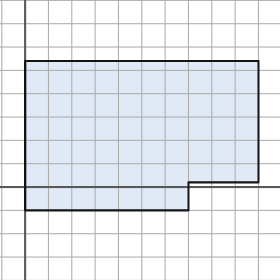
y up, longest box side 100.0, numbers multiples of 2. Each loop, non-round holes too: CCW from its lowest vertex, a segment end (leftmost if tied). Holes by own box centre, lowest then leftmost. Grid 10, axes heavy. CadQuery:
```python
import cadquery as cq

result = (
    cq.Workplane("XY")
    .moveTo(0.0, -10.0)
    .lineTo(70.0, -10.0)
    .lineTo(70.0, 2.0)
    .lineTo(100.0, 2.0)
    .lineTo(100.0, 54.0)
    .lineTo(0.0, 54.0)
    .close()
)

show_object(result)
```